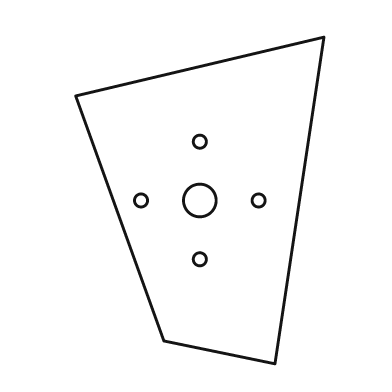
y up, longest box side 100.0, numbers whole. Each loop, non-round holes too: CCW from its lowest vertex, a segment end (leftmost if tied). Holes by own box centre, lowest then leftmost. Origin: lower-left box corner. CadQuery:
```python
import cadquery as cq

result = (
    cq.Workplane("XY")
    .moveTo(61.0, 0.0)
    .lineTo(76.0, 100.0)
    .lineTo(0.0, 82.0)
    .lineTo(27.0, 7.0)
    .close()
    .moveTo(38.0, 32.0)
    .circle(2.0)
    .moveTo(20.0, 50.0)
    .circle(2.0)
    .moveTo(38.0, 50.0)
    .circle(5.0)
    .moveTo(56.0, 50.0)
    .circle(2.0)
    .moveTo(38.0, 68.0)
    .circle(2.0)
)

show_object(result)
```